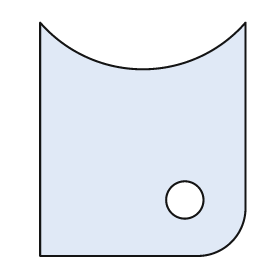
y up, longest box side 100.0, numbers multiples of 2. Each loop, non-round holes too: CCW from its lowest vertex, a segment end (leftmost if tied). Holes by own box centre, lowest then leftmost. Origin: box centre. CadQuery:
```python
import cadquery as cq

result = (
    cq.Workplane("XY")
    .moveTo(-44.0, -50.0)
    .lineTo(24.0, -50.0)
    .threePointArc((38.0, -44.0), (44.0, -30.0))
    .lineTo(44.0, 50.0)
    .threePointArc((0.0, 30.0), (-44.0, 50.0))
    .close()
    .moveTo(18.0, -26.0)
    .circle(8.0)
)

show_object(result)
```